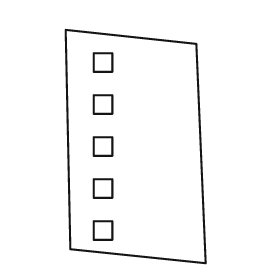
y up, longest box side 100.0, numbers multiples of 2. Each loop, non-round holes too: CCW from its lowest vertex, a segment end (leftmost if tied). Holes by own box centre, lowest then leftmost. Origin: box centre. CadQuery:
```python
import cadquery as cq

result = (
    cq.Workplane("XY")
    .moveTo(30.0, -50.0)
    .lineTo(26.0, 44.0)
    .lineTo(-30.0, 50.0)
    .lineTo(-28.0, -44.0)
    .close()
    .moveTo(-18.0, -40.0)
    .lineTo(-10.0, -40.0)
    .lineTo(-10.0, -32.0)
    .lineTo(-18.0, -32.0)
    .close()
    .moveTo(-18.0, -22.0)
    .lineTo(-10.0, -22.0)
    .lineTo(-10.0, -14.0)
    .lineTo(-18.0, -14.0)
    .close()
    .moveTo(-18.0, -4.0)
    .lineTo(-10.0, -4.0)
    .lineTo(-10.0, 4.0)
    .lineTo(-18.0, 4.0)
    .close()
    .moveTo(-18.0, 14.0)
    .lineTo(-10.0, 14.0)
    .lineTo(-10.0, 22.0)
    .lineTo(-18.0, 22.0)
    .close()
    .moveTo(-18.0, 32.0)
    .lineTo(-10.0, 32.0)
    .lineTo(-10.0, 40.0)
    .lineTo(-18.0, 40.0)
    .close()
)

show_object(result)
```